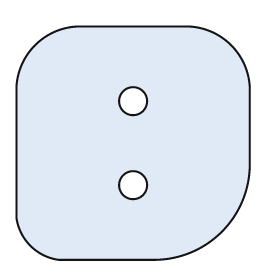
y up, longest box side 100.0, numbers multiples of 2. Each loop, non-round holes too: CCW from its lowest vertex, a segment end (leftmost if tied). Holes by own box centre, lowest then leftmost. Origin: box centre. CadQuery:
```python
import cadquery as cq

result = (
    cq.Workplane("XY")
    .moveTo(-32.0, -50.0)
    .lineTo(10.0, -50.0)
    .threePointArc((38.0, -38.0), (50.0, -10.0))
    .lineTo(50.0, 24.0)
    .threePointArc((42.0, 42.0), (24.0, 50.0))
    .lineTo(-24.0, 50.0)
    .threePointArc((-42.0, 42.0), (-50.0, 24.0))
    .lineTo(-50.0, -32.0)
    .threePointArc((-44.0, -44.0), (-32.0, -50.0))
    .close()
    .moveTo(0.0, -18.0)
    .circle(6.0)
    .moveTo(0.0, 18.0)
    .circle(6.0)
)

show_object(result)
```